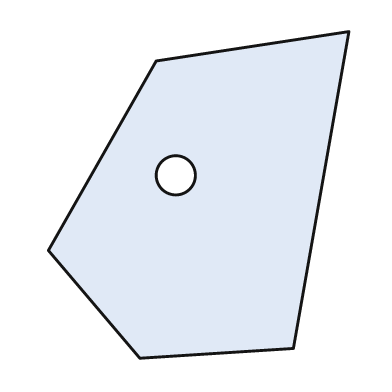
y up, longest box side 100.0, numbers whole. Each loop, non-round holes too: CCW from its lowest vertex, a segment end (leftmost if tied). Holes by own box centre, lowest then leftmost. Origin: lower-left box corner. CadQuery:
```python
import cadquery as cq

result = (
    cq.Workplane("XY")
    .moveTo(28.0, 0.0)
    .lineTo(75.0, 3.0)
    .lineTo(92.0, 100.0)
    .lineTo(33.0, 91.0)
    .lineTo(0.0, 33.0)
    .close()
    .moveTo(39.0, 56.0)
    .circle(6.0)
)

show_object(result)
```